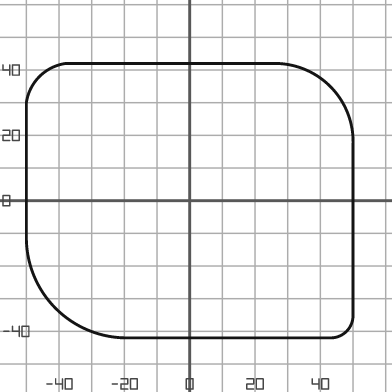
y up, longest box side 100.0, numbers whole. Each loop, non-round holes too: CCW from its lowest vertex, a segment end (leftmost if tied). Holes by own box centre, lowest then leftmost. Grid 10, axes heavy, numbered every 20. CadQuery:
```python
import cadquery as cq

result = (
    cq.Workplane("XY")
    .moveTo(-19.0, -42.0)
    .lineTo(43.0, -42.0)
    .threePointArc((48.0, -40.0), (50.0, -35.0))
    .lineTo(50.0, 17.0)
    .threePointArc((43.0, 35.0), (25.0, 42.0))
    .lineTo(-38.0, 42.0)
    .threePointArc((-46.0, 38.0), (-50.0, 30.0))
    .lineTo(-50.0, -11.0)
    .threePointArc((-41.0, -33.0), (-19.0, -42.0))
    .close()
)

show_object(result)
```